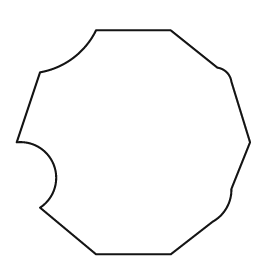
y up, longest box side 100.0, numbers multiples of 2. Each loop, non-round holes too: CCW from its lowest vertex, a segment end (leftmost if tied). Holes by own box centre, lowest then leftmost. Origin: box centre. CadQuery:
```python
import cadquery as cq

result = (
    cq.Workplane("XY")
    .moveTo(-16.0, -48.0)
    .lineTo(16.0, -48.0)
    .lineTo(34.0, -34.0)
    .threePointArc((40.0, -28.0), (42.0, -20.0))
    .lineTo(50.0, 0.0)
    .lineTo(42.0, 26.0)
    .threePointArc((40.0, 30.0), (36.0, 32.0))
    .lineTo(16.0, 48.0)
    .lineTo(-16.0, 48.0)
    .threePointArc((-26.0, 36.0), (-40.0, 30.0))
    .lineTo(-50.0, 0.0)
    .threePointArc((-34.0, -10.0), (-40.0, -28.0))
    .close()
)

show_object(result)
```